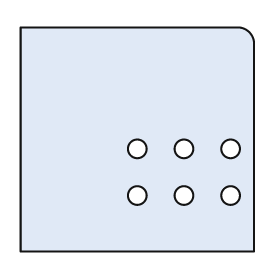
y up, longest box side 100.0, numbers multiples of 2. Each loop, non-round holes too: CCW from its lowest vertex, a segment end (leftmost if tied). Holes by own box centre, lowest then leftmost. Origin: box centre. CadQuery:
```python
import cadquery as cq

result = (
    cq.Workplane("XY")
    .moveTo(-50.0, -48.0)
    .lineTo(50.0, -48.0)
    .lineTo(50.0, 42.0)
    .threePointArc((48.0, 46.0), (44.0, 48.0))
    .lineTo(-50.0, 48.0)
    .close()
    .moveTo(0.0, -24.0)
    .circle(4.0)
    .moveTo(20.0, -24.0)
    .circle(4.0)
    .moveTo(40.0, -24.0)
    .circle(4.0)
    .moveTo(0.0, -4.0)
    .circle(4.0)
    .moveTo(20.0, -4.0)
    .circle(4.0)
    .moveTo(40.0, -4.0)
    .circle(4.0)
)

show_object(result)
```